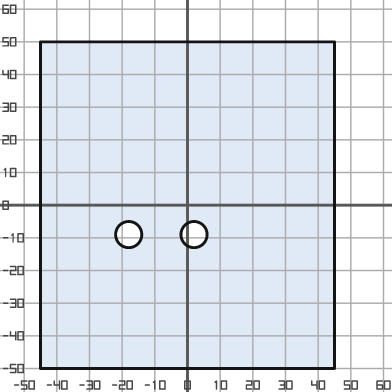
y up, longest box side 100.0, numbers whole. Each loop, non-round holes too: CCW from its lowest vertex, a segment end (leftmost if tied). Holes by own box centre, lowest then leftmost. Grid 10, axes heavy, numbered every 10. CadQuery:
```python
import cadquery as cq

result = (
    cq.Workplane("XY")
    .moveTo(-45.0, -50.0)
    .lineTo(45.0, -50.0)
    .lineTo(45.0, 50.0)
    .lineTo(-45.0, 50.0)
    .close()
    .moveTo(-18.0, -9.0)
    .circle(4.0)
    .moveTo(2.0, -9.0)
    .circle(4.0)
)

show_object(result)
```